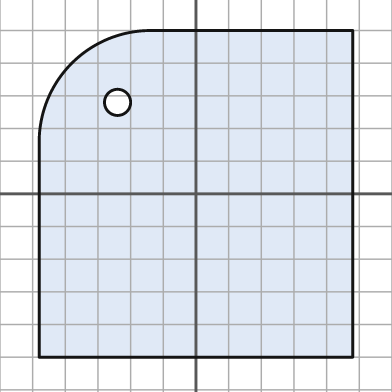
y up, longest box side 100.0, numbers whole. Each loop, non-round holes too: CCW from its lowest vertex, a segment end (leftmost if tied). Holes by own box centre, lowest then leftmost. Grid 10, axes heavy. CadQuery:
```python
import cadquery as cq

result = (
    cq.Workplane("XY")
    .moveTo(-48.0, -50.0)
    .lineTo(48.0, -50.0)
    .lineTo(48.0, 50.0)
    .lineTo(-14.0, 50.0)
    .threePointArc((-38.0, 40.0), (-48.0, 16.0))
    .close()
    .moveTo(-24.0, 28.0)
    .circle(4.0)
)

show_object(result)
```